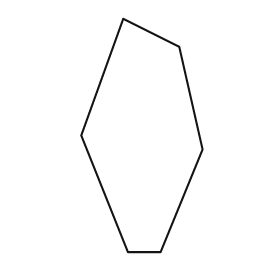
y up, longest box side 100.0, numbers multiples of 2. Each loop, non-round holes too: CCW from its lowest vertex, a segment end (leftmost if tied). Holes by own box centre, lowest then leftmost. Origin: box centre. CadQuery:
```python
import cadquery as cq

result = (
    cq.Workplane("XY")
    .moveTo(-6.0, -50.0)
    .lineTo(8.0, -50.0)
    .lineTo(26.0, -6.0)
    .lineTo(16.0, 38.0)
    .lineTo(-8.0, 50.0)
    .lineTo(-26.0, 0.0)
    .close()
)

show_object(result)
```